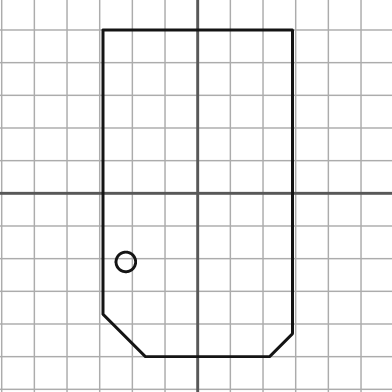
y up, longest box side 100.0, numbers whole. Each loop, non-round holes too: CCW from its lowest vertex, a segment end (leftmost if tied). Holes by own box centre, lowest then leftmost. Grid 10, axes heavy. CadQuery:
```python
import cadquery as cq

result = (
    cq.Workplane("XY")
    .moveTo(-16.0, -50.0)
    .lineTo(22.0, -50.0)
    .lineTo(29.0, -43.0)
    .lineTo(29.0, 50.0)
    .lineTo(-29.0, 50.0)
    .lineTo(-29.0, -37.0)
    .close()
    .moveTo(-22.0, -21.0)
    .circle(3.0)
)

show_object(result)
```